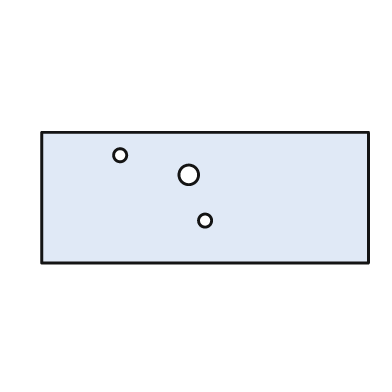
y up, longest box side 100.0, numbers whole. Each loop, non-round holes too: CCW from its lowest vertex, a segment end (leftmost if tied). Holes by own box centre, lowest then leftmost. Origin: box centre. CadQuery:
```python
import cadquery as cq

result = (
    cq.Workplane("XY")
    .moveTo(-50.0, -20.0)
    .lineTo(50.0, -20.0)
    .lineTo(50.0, 20.0)
    .lineTo(-50.0, 20.0)
    .close()
    .moveTo(0.0, -7.0)
    .circle(2.0)
    .moveTo(-5.0, 7.0)
    .circle(3.0)
    .moveTo(-26.0, 13.0)
    .circle(2.0)
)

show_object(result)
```